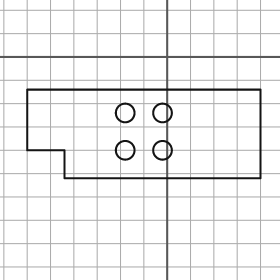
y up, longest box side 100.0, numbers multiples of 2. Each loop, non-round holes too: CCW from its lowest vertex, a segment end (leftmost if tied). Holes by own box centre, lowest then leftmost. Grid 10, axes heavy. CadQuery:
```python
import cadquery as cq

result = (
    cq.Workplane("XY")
    .moveTo(-44.0, -52.0)
    .lineTo(40.0, -52.0)
    .lineTo(40.0, -14.0)
    .lineTo(-60.0, -14.0)
    .lineTo(-60.0, -40.0)
    .lineTo(-44.0, -40.0)
    .close()
    .moveTo(-18.0, -40.0)
    .circle(4.0)
    .moveTo(-2.0, -40.0)
    .circle(4.0)
    .moveTo(-18.0, -24.0)
    .circle(4.0)
    .moveTo(-2.0, -24.0)
    .circle(4.0)
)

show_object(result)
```